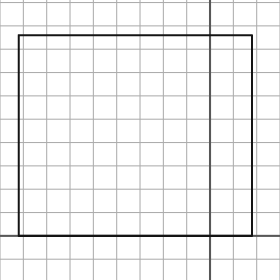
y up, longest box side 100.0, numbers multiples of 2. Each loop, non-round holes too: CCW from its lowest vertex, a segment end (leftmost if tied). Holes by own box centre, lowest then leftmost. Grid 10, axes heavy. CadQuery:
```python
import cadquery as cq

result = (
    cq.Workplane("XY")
    .moveTo(-82.0, 0.0)
    .lineTo(18.0, 0.0)
    .lineTo(18.0, 86.0)
    .lineTo(-82.0, 86.0)
    .close()
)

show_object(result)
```